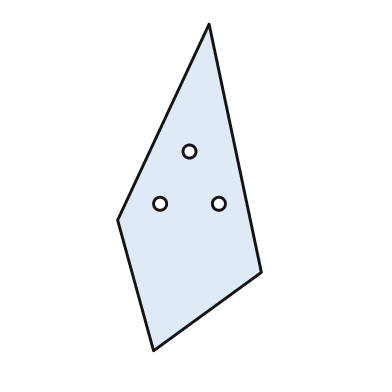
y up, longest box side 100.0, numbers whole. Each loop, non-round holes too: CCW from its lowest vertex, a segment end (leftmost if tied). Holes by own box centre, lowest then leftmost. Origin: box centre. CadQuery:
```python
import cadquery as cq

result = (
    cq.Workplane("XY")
    .moveTo(-11.0, -50.0)
    .lineTo(22.0, -26.0)
    .lineTo(6.0, 50.0)
    .lineTo(-22.0, -10.0)
    .close()
    .moveTo(-9.0, -5.0)
    .circle(2.0)
    .moveTo(9.0, -5.0)
    .circle(2.0)
    .moveTo(0.0, 11.0)
    .circle(2.0)
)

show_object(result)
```